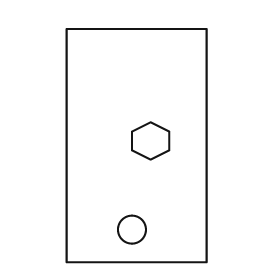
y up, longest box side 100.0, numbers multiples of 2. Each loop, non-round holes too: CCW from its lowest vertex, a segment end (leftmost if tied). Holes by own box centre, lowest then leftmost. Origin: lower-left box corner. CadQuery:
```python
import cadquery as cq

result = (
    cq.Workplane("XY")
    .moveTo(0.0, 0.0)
    .lineTo(60.0, 0.0)
    .lineTo(60.0, 100.0)
    .lineTo(0.0, 100.0)
    .close()
    .moveTo(28.0, 14.0)
    .circle(6.0)
    .moveTo(36.0, 44.0)
    .lineTo(44.0, 48.0)
    .lineTo(44.0, 56.0)
    .lineTo(36.0, 60.0)
    .lineTo(28.0, 56.0)
    .lineTo(28.0, 48.0)
    .close()
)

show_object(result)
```